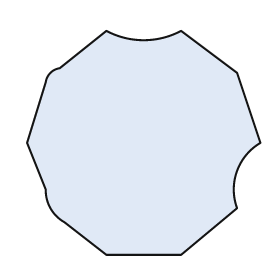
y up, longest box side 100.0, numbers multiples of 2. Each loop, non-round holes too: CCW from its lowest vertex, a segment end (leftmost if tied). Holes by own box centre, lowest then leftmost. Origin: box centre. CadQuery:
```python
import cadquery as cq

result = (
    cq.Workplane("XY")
    .moveTo(-16.0, -48.0)
    .lineTo(16.0, -48.0)
    .lineTo(40.0, -28.0)
    .threePointArc((40.0, -12.0), (50.0, 0.0))
    .lineTo(40.0, 30.0)
    .lineTo(16.0, 48.0)
    .threePointArc((0.0, 44.0), (-16.0, 48.0))
    .lineTo(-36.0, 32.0)
    .threePointArc((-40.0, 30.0), (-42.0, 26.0))
    .lineTo(-50.0, 0.0)
    .lineTo(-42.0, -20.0)
    .threePointArc((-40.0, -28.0), (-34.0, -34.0))
    .close()
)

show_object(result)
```